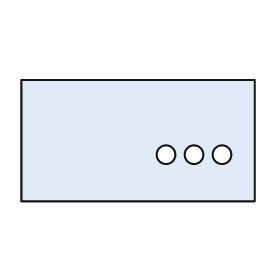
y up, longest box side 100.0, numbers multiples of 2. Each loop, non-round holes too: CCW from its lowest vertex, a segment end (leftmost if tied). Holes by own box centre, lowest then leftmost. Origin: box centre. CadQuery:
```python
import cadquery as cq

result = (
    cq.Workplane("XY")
    .moveTo(-50.0, -26.0)
    .lineTo(50.0, -26.0)
    .lineTo(50.0, 26.0)
    .lineTo(-50.0, 26.0)
    .close()
    .moveTo(12.0, -6.0)
    .circle(4.0)
    .moveTo(24.0, -6.0)
    .circle(4.0)
    .moveTo(36.0, -6.0)
    .circle(4.0)
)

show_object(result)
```